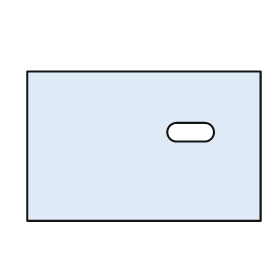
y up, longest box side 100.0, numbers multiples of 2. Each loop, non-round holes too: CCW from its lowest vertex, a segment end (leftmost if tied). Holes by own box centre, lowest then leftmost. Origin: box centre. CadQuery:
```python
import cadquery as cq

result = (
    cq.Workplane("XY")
    .moveTo(-50.0, -32.0)
    .lineTo(50.0, -32.0)
    .lineTo(50.0, 32.0)
    .lineTo(-50.0, 32.0)
    .close()
    .moveTo(14.0, 2.0)
    .lineTo(26.0, 2.0)
    .threePointArc((30.0, 6.0), (26.0, 10.0))
    .lineTo(14.0, 10.0)
    .threePointArc((10.0, 6.0), (14.0, 2.0))
    .close()
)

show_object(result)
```